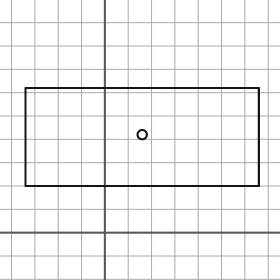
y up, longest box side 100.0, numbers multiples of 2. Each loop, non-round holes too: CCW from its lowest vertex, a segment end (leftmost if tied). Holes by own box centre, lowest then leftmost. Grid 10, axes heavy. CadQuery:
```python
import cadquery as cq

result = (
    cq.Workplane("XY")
    .moveTo(-34.0, 20.0)
    .lineTo(66.0, 20.0)
    .lineTo(66.0, 62.0)
    .lineTo(-34.0, 62.0)
    .close()
    .moveTo(16.0, 42.0)
    .circle(2.0)
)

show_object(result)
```